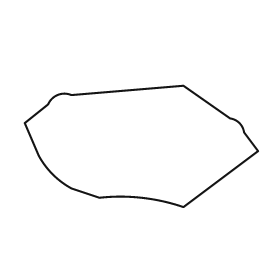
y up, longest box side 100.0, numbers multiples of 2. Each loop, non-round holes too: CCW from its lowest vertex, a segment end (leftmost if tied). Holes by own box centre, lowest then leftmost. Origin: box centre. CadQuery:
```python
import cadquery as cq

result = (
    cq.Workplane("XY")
    .moveTo(18.0, -26.0)
    .lineTo(50.0, -2.0)
    .lineTo(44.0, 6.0)
    .threePointArc((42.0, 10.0), (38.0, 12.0))
    .lineTo(18.0, 26.0)
    .lineTo(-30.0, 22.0)
    .threePointArc((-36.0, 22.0), (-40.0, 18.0))
    .lineTo(-50.0, 10.0)
    .lineTo(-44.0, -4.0)
    .threePointArc((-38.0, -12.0), (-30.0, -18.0))
    .lineTo(-18.0, -22.0)
    .threePointArc((0.0, -22.0), (18.0, -26.0))
    .close()
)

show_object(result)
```